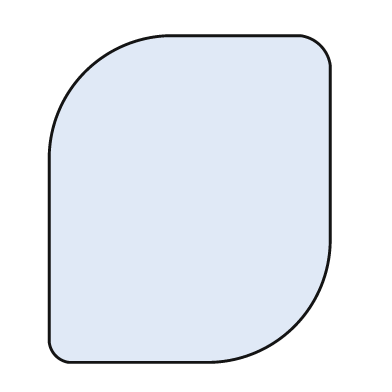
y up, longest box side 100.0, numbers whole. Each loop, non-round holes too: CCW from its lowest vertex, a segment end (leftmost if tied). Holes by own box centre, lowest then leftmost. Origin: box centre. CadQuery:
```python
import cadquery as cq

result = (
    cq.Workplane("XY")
    .moveTo(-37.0, -50.0)
    .lineTo(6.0, -50.0)
    .threePointArc((32.0, -39.0), (43.0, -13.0))
    .lineTo(43.0, 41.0)
    .threePointArc((40.0, 47.0), (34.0, 50.0))
    .lineTo(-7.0, 50.0)
    .threePointArc((-32.0, 39.0), (-43.0, 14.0))
    .lineTo(-43.0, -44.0)
    .threePointArc((-41.0, -48.0), (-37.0, -50.0))
    .close()
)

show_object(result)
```